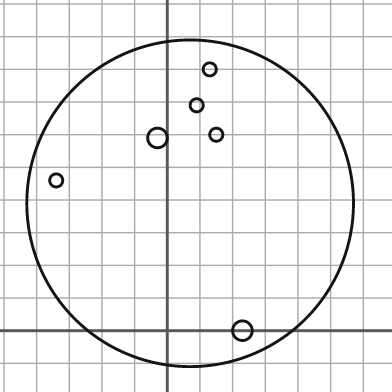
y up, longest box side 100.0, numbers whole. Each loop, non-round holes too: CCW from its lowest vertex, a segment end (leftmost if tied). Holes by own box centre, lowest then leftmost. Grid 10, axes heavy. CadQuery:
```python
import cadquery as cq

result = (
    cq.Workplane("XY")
    .moveTo(7.0, 39.0)
    .circle(50.0)
    .moveTo(23.0, 0.0)
    .circle(3.0)
    .moveTo(-34.0, 46.0)
    .circle(2.0)
    .moveTo(-3.0, 59.0)
    .circle(3.0)
    .moveTo(15.0, 60.0)
    .circle(2.0)
    .moveTo(9.0, 69.0)
    .circle(2.0)
    .moveTo(13.0, 80.0)
    .circle(2.0)
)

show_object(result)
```